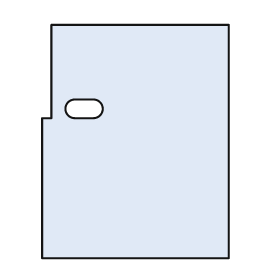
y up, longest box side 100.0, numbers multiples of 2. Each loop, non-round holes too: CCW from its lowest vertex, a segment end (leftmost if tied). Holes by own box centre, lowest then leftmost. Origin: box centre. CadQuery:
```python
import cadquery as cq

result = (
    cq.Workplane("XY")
    .moveTo(-40.0, -50.0)
    .lineTo(40.0, -50.0)
    .lineTo(40.0, 50.0)
    .lineTo(-36.0, 50.0)
    .lineTo(-36.0, 10.0)
    .lineTo(-40.0, 10.0)
    .close()
    .moveTo(-26.0, 10.0)
    .lineTo(-18.0, 10.0)
    .threePointArc((-14.0, 14.0), (-18.0, 18.0))
    .lineTo(-26.0, 18.0)
    .threePointArc((-30.0, 14.0), (-26.0, 10.0))
    .close()
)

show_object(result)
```